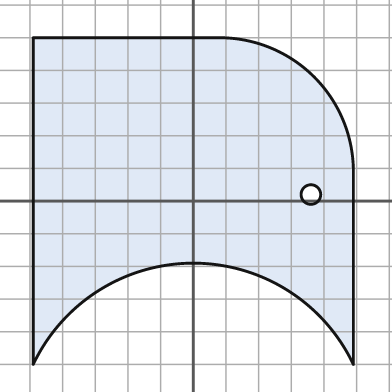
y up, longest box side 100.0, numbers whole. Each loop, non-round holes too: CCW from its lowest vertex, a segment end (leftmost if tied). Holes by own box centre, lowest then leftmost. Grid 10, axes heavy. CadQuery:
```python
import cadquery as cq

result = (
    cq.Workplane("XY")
    .moveTo(-49.0, -50.0)
    .threePointArc((0.0, -19.0), (49.0, -50.0))
    .lineTo(49.0, 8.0)
    .threePointArc((37.0, 38.0), (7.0, 50.0))
    .lineTo(-49.0, 50.0)
    .close()
    .moveTo(36.0, 2.0)
    .circle(3.0)
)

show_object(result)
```